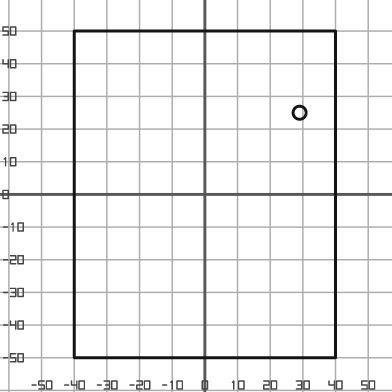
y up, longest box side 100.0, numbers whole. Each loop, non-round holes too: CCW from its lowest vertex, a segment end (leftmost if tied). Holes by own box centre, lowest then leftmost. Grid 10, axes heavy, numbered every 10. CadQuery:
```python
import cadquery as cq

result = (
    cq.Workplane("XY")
    .moveTo(-40.0, -50.0)
    .lineTo(40.0, -50.0)
    .lineTo(40.0, 50.0)
    .lineTo(-40.0, 50.0)
    .close()
    .moveTo(29.0, 25.0)
    .circle(2.0)
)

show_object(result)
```